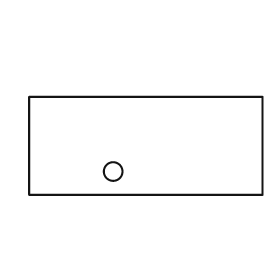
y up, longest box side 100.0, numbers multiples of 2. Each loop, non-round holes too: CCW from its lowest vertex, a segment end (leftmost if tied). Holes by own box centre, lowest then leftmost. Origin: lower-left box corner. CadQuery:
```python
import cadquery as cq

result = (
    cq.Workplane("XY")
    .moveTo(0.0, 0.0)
    .lineTo(100.0, 0.0)
    .lineTo(100.0, 42.0)
    .lineTo(0.0, 42.0)
    .close()
    .moveTo(36.0, 10.0)
    .circle(4.0)
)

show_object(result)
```